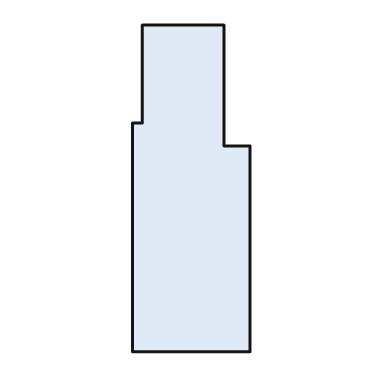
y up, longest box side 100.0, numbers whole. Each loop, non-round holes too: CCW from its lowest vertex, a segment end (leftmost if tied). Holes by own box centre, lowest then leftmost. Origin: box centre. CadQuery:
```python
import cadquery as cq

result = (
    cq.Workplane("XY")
    .moveTo(-18.0, -50.0)
    .lineTo(18.0, -50.0)
    .lineTo(18.0, 13.0)
    .lineTo(10.0, 13.0)
    .lineTo(10.0, 50.0)
    .lineTo(-15.0, 50.0)
    .lineTo(-15.0, 20.0)
    .lineTo(-18.0, 20.0)
    .close()
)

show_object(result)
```